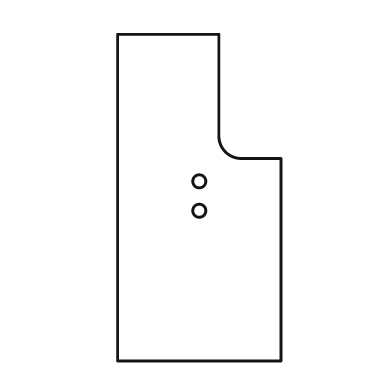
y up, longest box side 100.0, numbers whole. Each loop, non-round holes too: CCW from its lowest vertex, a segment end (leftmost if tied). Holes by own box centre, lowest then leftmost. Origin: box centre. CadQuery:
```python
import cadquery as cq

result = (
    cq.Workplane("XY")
    .moveTo(-25.0, -50.0)
    .lineTo(25.0, -50.0)
    .lineTo(25.0, 12.0)
    .lineTo(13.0, 12.0)
    .threePointArc((8.0, 14.0), (6.0, 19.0))
    .lineTo(6.0, 50.0)
    .lineTo(-25.0, 50.0)
    .close()
    .moveTo(0.0, -4.0)
    .circle(2.0)
    .moveTo(0.0, 5.0)
    .circle(2.0)
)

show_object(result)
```